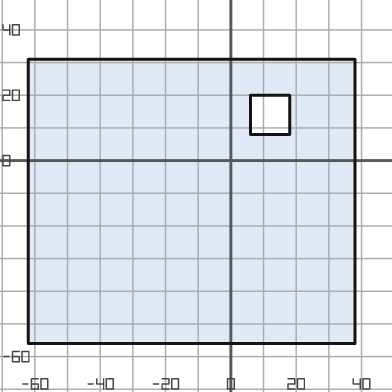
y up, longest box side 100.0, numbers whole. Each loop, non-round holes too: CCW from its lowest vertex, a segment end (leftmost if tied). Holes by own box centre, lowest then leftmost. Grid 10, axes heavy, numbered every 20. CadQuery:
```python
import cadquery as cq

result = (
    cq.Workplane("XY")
    .moveTo(-62.0, -56.0)
    .lineTo(38.0, -56.0)
    .lineTo(38.0, 31.0)
    .lineTo(-62.0, 31.0)
    .close()
    .moveTo(6.0, 8.0)
    .lineTo(18.0, 8.0)
    .lineTo(18.0, 20.0)
    .lineTo(6.0, 20.0)
    .close()
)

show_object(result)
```